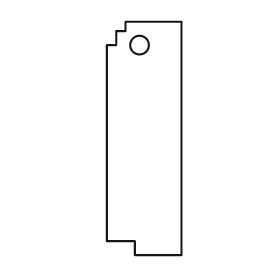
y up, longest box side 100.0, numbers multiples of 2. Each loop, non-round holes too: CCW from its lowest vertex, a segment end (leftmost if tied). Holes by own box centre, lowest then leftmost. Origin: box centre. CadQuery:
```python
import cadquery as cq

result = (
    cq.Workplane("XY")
    .moveTo(-4.0, -50.0)
    .lineTo(16.0, -50.0)
    .lineTo(16.0, 50.0)
    .lineTo(-8.0, 50.0)
    .lineTo(-8.0, 46.0)
    .lineTo(-12.0, 46.0)
    .lineTo(-12.0, 40.0)
    .lineTo(-16.0, 40.0)
    .lineTo(-16.0, -44.0)
    .lineTo(-4.0, -44.0)
    .close()
    .moveTo(-2.0, 40.0)
    .circle(4.0)
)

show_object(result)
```